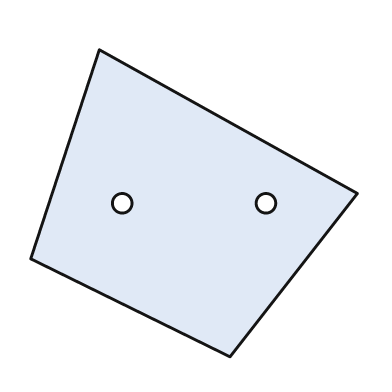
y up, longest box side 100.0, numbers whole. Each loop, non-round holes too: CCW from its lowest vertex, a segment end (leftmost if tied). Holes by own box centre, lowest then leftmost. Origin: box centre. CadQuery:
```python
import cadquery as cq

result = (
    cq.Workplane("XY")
    .moveTo(11.0, -47.0)
    .lineTo(50.0, 3.0)
    .lineTo(-29.0, 47.0)
    .lineTo(-50.0, -17.0)
    .close()
    .moveTo(-22.0, 0.0)
    .circle(3.0)
    .moveTo(22.0, 0.0)
    .circle(3.0)
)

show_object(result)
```